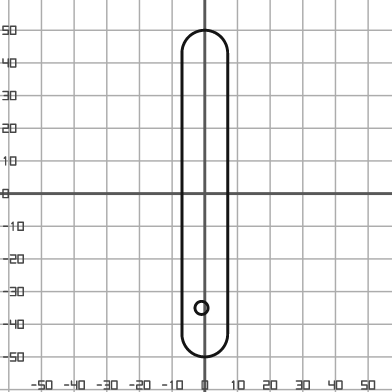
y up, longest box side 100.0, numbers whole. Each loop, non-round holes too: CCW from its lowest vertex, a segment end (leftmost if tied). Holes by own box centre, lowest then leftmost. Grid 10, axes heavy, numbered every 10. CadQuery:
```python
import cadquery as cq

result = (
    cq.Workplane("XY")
    .moveTo(-7.0, -43.0)
    .threePointArc((0.0, -50.0), (7.0, -43.0))
    .lineTo(7.0, 43.0)
    .threePointArc((0.0, 50.0), (-7.0, 43.0))
    .close()
    .moveTo(-1.0, -35.0)
    .circle(2.0)
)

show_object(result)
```